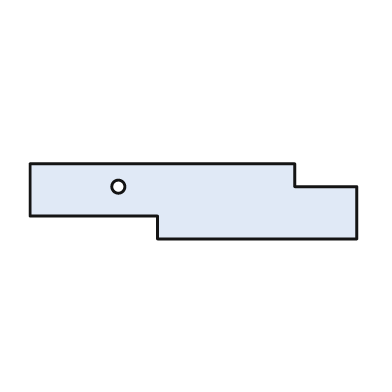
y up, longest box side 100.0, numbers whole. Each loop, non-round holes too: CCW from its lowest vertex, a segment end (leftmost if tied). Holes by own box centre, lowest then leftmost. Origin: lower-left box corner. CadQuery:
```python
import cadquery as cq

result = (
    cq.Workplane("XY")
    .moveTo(39.0, 0.0)
    .lineTo(100.0, 0.0)
    .lineTo(100.0, 16.0)
    .lineTo(81.0, 16.0)
    .lineTo(81.0, 23.0)
    .lineTo(0.0, 23.0)
    .lineTo(0.0, 7.0)
    .lineTo(39.0, 7.0)
    .close()
    .moveTo(27.0, 16.0)
    .circle(2.0)
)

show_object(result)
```